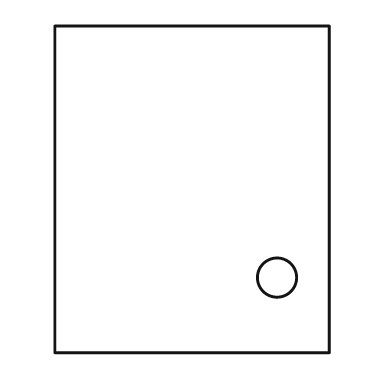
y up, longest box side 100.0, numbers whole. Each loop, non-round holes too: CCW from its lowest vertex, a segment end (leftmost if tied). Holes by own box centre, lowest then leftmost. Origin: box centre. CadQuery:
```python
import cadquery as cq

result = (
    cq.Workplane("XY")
    .moveTo(-42.0, -50.0)
    .lineTo(42.0, -50.0)
    .lineTo(42.0, 50.0)
    .lineTo(-42.0, 50.0)
    .close()
    .moveTo(26.0, -27.0)
    .circle(6.0)
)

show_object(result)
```